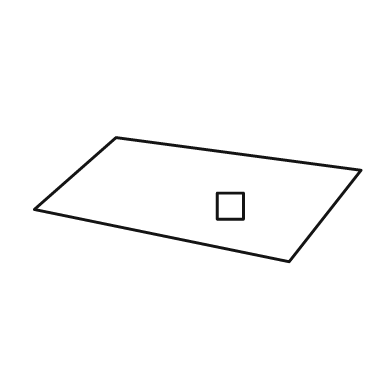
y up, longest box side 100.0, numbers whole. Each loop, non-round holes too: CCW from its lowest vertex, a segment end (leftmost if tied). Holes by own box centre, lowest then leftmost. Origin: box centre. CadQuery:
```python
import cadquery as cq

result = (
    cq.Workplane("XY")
    .moveTo(28.0, -19.0)
    .lineTo(50.0, 9.0)
    .lineTo(-25.0, 19.0)
    .lineTo(-50.0, -3.0)
    .close()
    .moveTo(6.0, -6.0)
    .lineTo(14.0, -6.0)
    .lineTo(14.0, 2.0)
    .lineTo(6.0, 2.0)
    .close()
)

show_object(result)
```